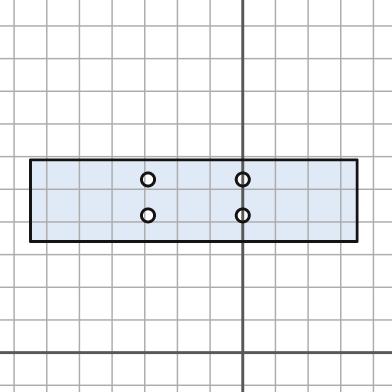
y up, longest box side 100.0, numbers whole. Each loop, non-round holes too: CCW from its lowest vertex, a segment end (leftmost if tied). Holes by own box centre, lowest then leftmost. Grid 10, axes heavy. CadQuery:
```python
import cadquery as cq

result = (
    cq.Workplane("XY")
    .moveTo(-65.0, 34.0)
    .lineTo(35.0, 34.0)
    .lineTo(35.0, 59.0)
    .lineTo(-65.0, 59.0)
    .close()
    .moveTo(-29.0, 42.0)
    .circle(2.0)
    .moveTo(0.0, 42.0)
    .circle(2.0)
    .moveTo(-29.0, 53.0)
    .circle(2.0)
    .moveTo(0.0, 53.0)
    .circle(2.0)
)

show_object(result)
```